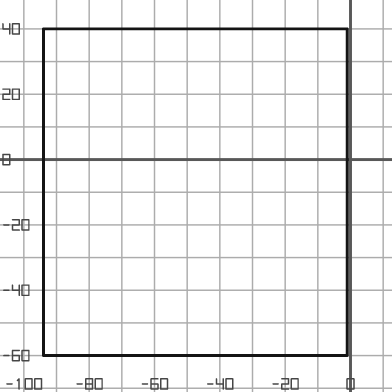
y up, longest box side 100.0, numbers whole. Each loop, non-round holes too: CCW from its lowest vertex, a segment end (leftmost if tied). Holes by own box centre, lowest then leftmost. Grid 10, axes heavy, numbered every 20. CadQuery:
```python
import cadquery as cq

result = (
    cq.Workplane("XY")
    .moveTo(-94.0, -60.0)
    .lineTo(-1.0, -60.0)
    .lineTo(-1.0, 40.0)
    .lineTo(-94.0, 40.0)
    .close()
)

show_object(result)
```